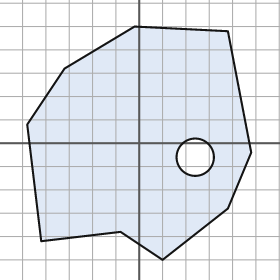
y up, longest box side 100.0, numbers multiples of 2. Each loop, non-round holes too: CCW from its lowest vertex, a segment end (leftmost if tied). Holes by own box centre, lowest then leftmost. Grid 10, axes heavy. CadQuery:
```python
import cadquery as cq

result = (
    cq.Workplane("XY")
    .moveTo(10.0, -50.0)
    .lineTo(38.0, -28.0)
    .lineTo(48.0, -4.0)
    .lineTo(38.0, 48.0)
    .lineTo(-2.0, 50.0)
    .lineTo(-32.0, 32.0)
    .lineTo(-48.0, 8.0)
    .lineTo(-42.0, -42.0)
    .lineTo(-8.0, -38.0)
    .close()
    .moveTo(24.0, -6.0)
    .circle(8.0)
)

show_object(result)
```